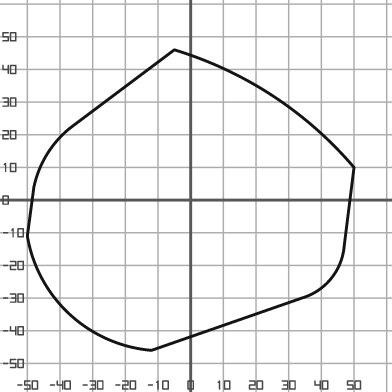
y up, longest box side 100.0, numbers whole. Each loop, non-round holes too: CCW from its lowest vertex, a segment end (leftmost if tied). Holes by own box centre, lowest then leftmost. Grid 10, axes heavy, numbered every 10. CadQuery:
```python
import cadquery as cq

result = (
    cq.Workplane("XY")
    .moveTo(-12.0, -46.0)
    .lineTo(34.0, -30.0)
    .threePointArc((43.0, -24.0), (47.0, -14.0))
    .lineTo(50.0, 10.0)
    .threePointArc((25.0, 32.0), (-5.0, 46.0))
    .lineTo(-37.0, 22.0)
    .threePointArc((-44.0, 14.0), (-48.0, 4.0))
    .lineTo(-50.0, -11.0)
    .threePointArc((-37.0, -35.0), (-12.0, -46.0))
    .close()
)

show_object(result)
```